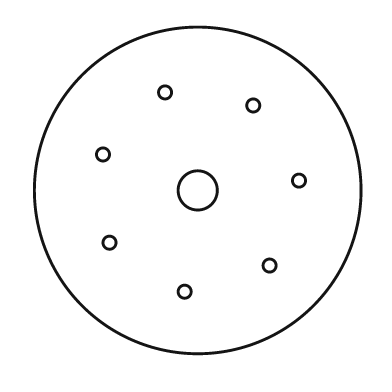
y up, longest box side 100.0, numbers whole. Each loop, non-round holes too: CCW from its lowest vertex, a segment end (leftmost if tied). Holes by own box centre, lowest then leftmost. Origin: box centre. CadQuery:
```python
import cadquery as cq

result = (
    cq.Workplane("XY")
    .moveTo(0.0, 0.0)
    .circle(50.0)
    .moveTo(-4.0, -31.0)
    .circle(2.0)
    .moveTo(22.0, -23.0)
    .circle(2.0)
    .moveTo(-27.0, -16.0)
    .circle(2.0)
    .moveTo(0.0, 0.0)
    .circle(6.0)
    .moveTo(31.0, 3.0)
    .circle(2.0)
    .moveTo(-29.0, 11.0)
    .circle(2.0)
    .moveTo(17.0, 26.0)
    .circle(2.0)
    .moveTo(-10.0, 30.0)
    .circle(2.0)
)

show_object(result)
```